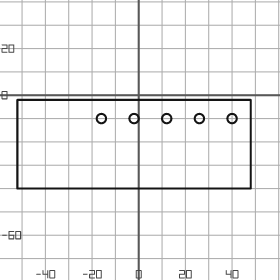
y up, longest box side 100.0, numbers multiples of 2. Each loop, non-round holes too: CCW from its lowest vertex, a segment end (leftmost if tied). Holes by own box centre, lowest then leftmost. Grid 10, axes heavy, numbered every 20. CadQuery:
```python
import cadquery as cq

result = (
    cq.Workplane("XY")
    .moveTo(-52.0, -40.0)
    .lineTo(48.0, -40.0)
    .lineTo(48.0, -2.0)
    .lineTo(-52.0, -2.0)
    .close()
    .moveTo(-16.0, -10.0)
    .circle(2.0)
    .moveTo(-2.0, -10.0)
    .circle(2.0)
    .moveTo(12.0, -10.0)
    .circle(2.0)
    .moveTo(26.0, -10.0)
    .circle(2.0)
    .moveTo(40.0, -10.0)
    .circle(2.0)
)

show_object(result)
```